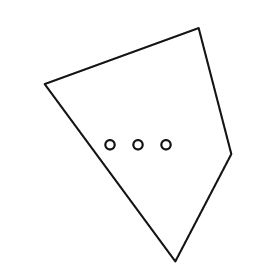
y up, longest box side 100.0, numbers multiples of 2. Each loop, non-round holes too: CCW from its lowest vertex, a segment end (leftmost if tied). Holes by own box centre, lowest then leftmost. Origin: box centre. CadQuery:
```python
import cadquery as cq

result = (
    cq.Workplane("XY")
    .moveTo(16.0, -50.0)
    .lineTo(40.0, -4.0)
    .lineTo(26.0, 50.0)
    .lineTo(-40.0, 26.0)
    .close()
    .moveTo(-12.0, 0.0)
    .circle(2.0)
    .moveTo(0.0, 0.0)
    .circle(2.0)
    .moveTo(12.0, 0.0)
    .circle(2.0)
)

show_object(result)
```